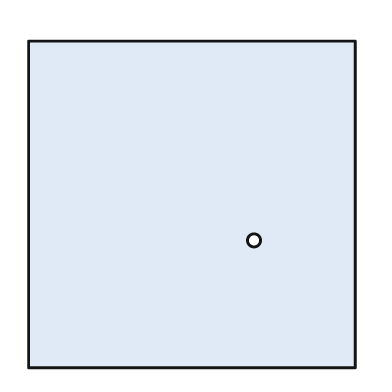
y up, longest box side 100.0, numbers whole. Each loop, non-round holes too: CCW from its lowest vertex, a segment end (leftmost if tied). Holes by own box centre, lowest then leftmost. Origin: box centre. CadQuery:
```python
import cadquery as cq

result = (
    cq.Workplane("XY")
    .moveTo(-50.0, -50.0)
    .lineTo(50.0, -50.0)
    .lineTo(50.0, 50.0)
    .lineTo(-50.0, 50.0)
    .close()
    .moveTo(19.0, -11.0)
    .circle(2.0)
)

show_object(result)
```